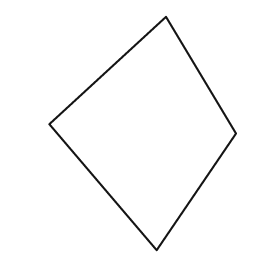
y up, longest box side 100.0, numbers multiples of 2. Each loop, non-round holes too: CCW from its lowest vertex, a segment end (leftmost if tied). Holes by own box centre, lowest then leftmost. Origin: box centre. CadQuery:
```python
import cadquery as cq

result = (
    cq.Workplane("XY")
    .moveTo(6.0, -50.0)
    .lineTo(40.0, 0.0)
    .lineTo(10.0, 50.0)
    .lineTo(-40.0, 4.0)
    .close()
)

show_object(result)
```